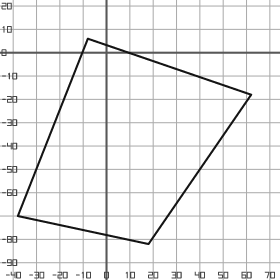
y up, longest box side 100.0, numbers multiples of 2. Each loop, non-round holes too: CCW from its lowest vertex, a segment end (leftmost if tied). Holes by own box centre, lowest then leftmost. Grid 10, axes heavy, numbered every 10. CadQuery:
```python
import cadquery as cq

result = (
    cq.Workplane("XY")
    .moveTo(18.0, -82.0)
    .lineTo(62.0, -18.0)
    .lineTo(-8.0, 6.0)
    .lineTo(-38.0, -70.0)
    .close()
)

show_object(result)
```